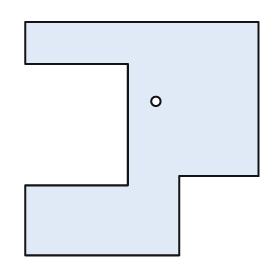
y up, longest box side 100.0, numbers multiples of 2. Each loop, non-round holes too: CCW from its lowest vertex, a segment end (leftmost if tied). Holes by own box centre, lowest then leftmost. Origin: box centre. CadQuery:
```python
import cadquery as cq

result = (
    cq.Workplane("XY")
    .moveTo(-50.0, -50.0)
    .lineTo(16.0, -50.0)
    .lineTo(16.0, -16.0)
    .lineTo(50.0, -16.0)
    .lineTo(50.0, 50.0)
    .lineTo(-50.0, 50.0)
    .lineTo(-50.0, 32.0)
    .lineTo(-6.0, 32.0)
    .lineTo(-6.0, -20.0)
    .lineTo(-50.0, -20.0)
    .close()
    .moveTo(6.0, 16.0)
    .circle(2.0)
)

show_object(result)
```